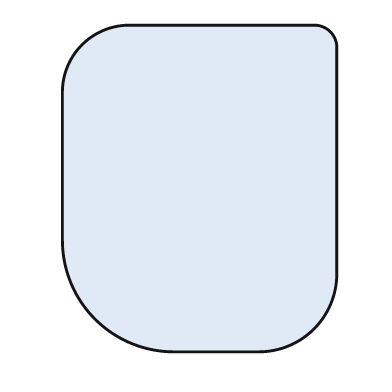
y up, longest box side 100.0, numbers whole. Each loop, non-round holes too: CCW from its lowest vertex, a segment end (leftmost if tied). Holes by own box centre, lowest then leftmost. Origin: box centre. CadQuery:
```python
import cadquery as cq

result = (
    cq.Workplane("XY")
    .moveTo(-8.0, -50.0)
    .lineTo(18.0, -50.0)
    .threePointArc((35.0, -43.0), (42.0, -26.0))
    .lineTo(42.0, 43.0)
    .threePointArc((40.0, 48.0), (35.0, 50.0))
    .lineTo(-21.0, 50.0)
    .threePointArc((-36.0, 44.0), (-42.0, 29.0))
    .lineTo(-42.0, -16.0)
    .threePointArc((-32.0, -40.0), (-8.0, -50.0))
    .close()
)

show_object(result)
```